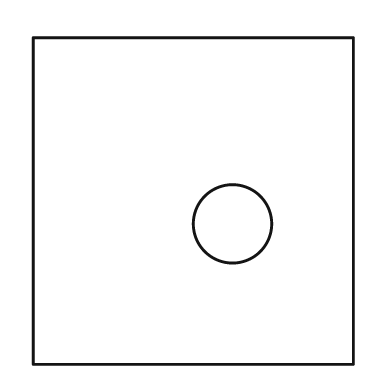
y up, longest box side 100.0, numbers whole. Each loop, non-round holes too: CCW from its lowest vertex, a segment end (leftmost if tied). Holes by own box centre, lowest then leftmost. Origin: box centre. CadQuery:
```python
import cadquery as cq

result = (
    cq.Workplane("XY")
    .moveTo(-49.0, -50.0)
    .lineTo(49.0, -50.0)
    .lineTo(49.0, 50.0)
    .lineTo(-49.0, 50.0)
    .close()
    .moveTo(12.0, -7.0)
    .circle(12.0)
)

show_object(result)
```